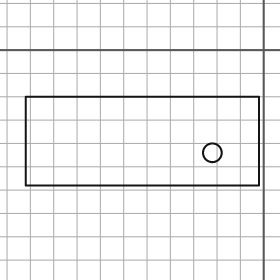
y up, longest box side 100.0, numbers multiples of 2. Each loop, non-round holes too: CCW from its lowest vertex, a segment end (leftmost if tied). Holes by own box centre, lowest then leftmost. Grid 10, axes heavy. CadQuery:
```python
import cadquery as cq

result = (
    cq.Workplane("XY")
    .moveTo(-102.0, -58.0)
    .lineTo(-2.0, -58.0)
    .lineTo(-2.0, -20.0)
    .lineTo(-102.0, -20.0)
    .close()
    .moveTo(-22.0, -44.0)
    .circle(4.0)
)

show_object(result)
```